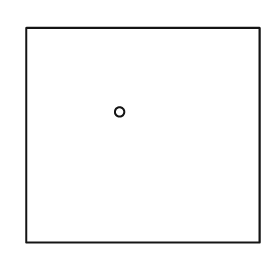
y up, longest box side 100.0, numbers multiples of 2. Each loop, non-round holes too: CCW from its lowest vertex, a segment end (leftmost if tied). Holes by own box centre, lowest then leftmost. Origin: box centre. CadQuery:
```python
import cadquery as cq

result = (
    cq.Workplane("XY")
    .moveTo(-50.0, -46.0)
    .lineTo(50.0, -46.0)
    .lineTo(50.0, 46.0)
    .lineTo(-50.0, 46.0)
    .close()
    .moveTo(-10.0, 10.0)
    .circle(2.0)
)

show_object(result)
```